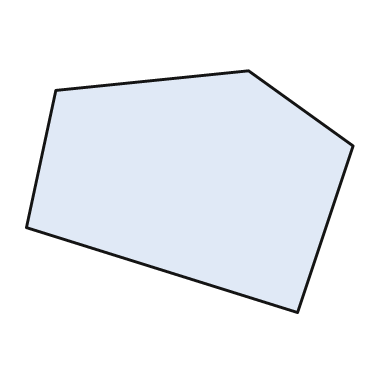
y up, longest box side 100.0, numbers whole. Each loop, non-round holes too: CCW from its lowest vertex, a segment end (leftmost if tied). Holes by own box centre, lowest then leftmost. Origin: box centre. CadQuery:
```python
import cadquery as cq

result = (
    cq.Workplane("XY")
    .moveTo(33.0, -37.0)
    .lineTo(50.0, 14.0)
    .lineTo(18.0, 37.0)
    .lineTo(-41.0, 31.0)
    .lineTo(-50.0, -11.0)
    .close()
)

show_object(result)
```